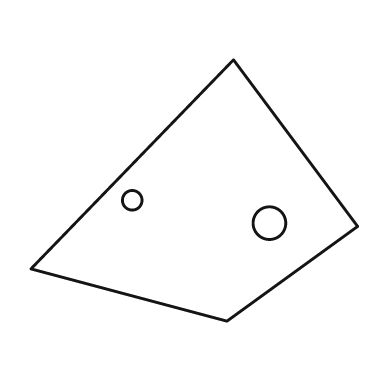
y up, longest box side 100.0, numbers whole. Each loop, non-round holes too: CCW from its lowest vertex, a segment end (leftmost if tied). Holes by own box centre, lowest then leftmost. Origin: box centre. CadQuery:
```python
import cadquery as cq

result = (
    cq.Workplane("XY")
    .moveTo(10.0, -40.0)
    .lineTo(50.0, -11.0)
    .lineTo(12.0, 40.0)
    .lineTo(-50.0, -24.0)
    .close()
    .moveTo(23.0, -10.0)
    .circle(5.0)
    .moveTo(-19.0, -3.0)
    .circle(3.0)
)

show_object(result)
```